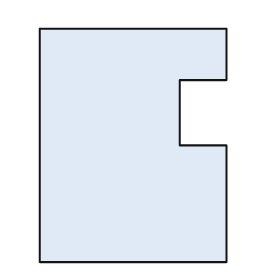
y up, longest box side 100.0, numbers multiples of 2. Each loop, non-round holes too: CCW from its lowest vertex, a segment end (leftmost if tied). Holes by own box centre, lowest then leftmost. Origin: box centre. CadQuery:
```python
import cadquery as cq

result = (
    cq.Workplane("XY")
    .moveTo(-40.0, -50.0)
    .lineTo(40.0, -50.0)
    .lineTo(40.0, 0.0)
    .lineTo(20.0, 0.0)
    .lineTo(20.0, 28.0)
    .lineTo(40.0, 28.0)
    .lineTo(40.0, 50.0)
    .lineTo(-40.0, 50.0)
    .close()
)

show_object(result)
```